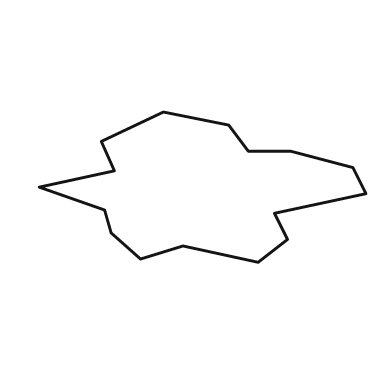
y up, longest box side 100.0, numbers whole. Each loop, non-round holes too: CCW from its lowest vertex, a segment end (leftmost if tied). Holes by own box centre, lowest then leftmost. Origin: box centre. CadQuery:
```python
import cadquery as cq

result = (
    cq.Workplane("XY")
    .moveTo(17.0, -23.0)
    .lineTo(26.0, -16.0)
    .lineTo(22.0, -8.0)
    .lineTo(50.0, -2.0)
    .lineTo(46.0, 6.0)
    .lineTo(27.0, 11.0)
    .lineTo(14.0, 11.0)
    .lineTo(8.0, 19.0)
    .lineTo(-12.0, 23.0)
    .lineTo(-31.0, 14.0)
    .lineTo(-27.0, 5.0)
    .lineTo(-50.0, 0.0)
    .lineTo(-30.0, -7.0)
    .lineTo(-28.0, -14.0)
    .lineTo(-19.0, -22.0)
    .lineTo(-6.0, -18.0)
    .close()
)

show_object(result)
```